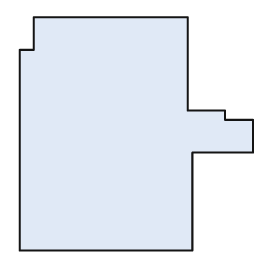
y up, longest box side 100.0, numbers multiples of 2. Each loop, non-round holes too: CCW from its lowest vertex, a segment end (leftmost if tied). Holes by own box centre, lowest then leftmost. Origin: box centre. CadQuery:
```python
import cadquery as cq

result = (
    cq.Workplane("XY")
    .moveTo(-50.0, -50.0)
    .lineTo(24.0, -50.0)
    .lineTo(24.0, -8.0)
    .lineTo(50.0, -8.0)
    .lineTo(50.0, 6.0)
    .lineTo(38.0, 6.0)
    .lineTo(38.0, 10.0)
    .lineTo(22.0, 10.0)
    .lineTo(22.0, 50.0)
    .lineTo(-44.0, 50.0)
    .lineTo(-44.0, 36.0)
    .lineTo(-50.0, 36.0)
    .close()
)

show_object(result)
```